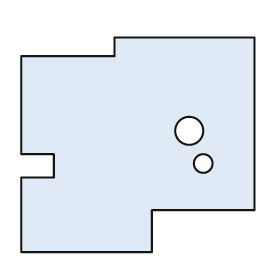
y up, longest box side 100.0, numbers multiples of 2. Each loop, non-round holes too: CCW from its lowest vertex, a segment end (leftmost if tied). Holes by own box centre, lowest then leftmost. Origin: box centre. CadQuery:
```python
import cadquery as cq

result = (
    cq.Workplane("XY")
    .moveTo(-50.0, -46.0)
    .lineTo(6.0, -46.0)
    .lineTo(6.0, -28.0)
    .lineTo(50.0, -28.0)
    .lineTo(50.0, 46.0)
    .lineTo(-10.0, 46.0)
    .lineTo(-10.0, 38.0)
    .lineTo(-50.0, 38.0)
    .lineTo(-50.0, -4.0)
    .lineTo(-36.0, -4.0)
    .lineTo(-36.0, -14.0)
    .lineTo(-50.0, -14.0)
    .close()
    .moveTo(28.0, -8.0)
    .circle(4.0)
    .moveTo(22.0, 6.0)
    .circle(6.0)
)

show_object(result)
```